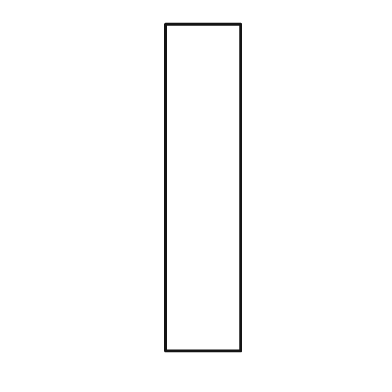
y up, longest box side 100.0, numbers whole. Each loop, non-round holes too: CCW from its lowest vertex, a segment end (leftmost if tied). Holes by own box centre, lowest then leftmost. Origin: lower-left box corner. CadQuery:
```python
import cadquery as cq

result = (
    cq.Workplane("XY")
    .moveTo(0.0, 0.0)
    .lineTo(23.0, 0.0)
    .lineTo(23.0, 100.0)
    .lineTo(0.0, 100.0)
    .close()
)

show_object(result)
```